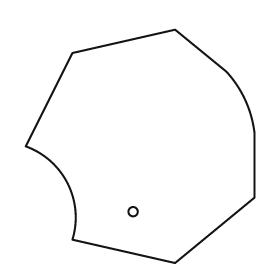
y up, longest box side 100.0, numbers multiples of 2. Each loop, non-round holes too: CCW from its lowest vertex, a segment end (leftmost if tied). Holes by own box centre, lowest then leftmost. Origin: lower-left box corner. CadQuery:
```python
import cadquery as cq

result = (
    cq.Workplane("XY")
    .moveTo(64.0, 0.0)
    .lineTo(98.0, 28.0)
    .lineTo(98.0, 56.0)
    .threePointArc((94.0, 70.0), (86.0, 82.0))
    .lineTo(64.0, 100.0)
    .lineTo(20.0, 90.0)
    .lineTo(0.0, 50.0)
    .threePointArc((18.0, 34.0), (20.0, 10.0))
    .close()
    .moveTo(46.0, 22.0)
    .circle(2.0)
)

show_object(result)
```